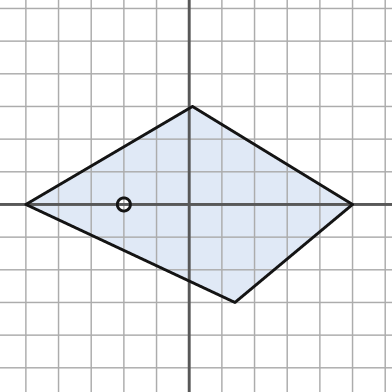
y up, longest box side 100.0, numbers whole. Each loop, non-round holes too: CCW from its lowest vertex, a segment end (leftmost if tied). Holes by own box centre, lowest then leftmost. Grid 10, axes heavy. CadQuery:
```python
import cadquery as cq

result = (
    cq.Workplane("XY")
    .moveTo(14.0, -30.0)
    .lineTo(50.0, 0.0)
    .lineTo(1.0, 30.0)
    .lineTo(-50.0, 0.0)
    .close()
    .moveTo(-20.0, 0.0)
    .circle(2.0)
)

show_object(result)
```